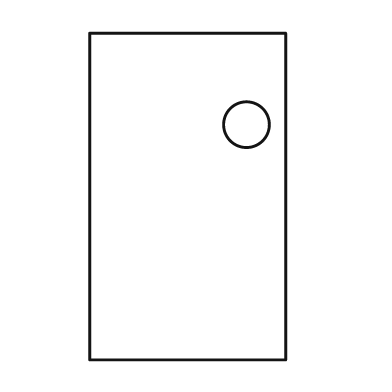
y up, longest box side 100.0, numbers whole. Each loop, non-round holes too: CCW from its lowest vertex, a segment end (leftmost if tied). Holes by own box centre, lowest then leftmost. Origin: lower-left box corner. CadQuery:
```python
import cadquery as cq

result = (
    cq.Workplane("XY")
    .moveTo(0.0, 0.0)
    .lineTo(60.0, 0.0)
    .lineTo(60.0, 100.0)
    .lineTo(0.0, 100.0)
    .close()
    .moveTo(48.0, 72.0)
    .circle(7.0)
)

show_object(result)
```